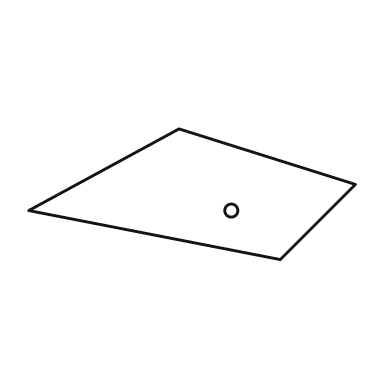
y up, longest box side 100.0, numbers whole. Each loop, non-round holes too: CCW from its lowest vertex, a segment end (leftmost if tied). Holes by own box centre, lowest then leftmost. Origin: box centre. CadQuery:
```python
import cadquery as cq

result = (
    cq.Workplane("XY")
    .moveTo(27.0, -20.0)
    .lineTo(50.0, 3.0)
    .lineTo(-4.0, 20.0)
    .lineTo(-50.0, -5.0)
    .close()
    .moveTo(12.0, -5.0)
    .circle(2.0)
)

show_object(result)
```